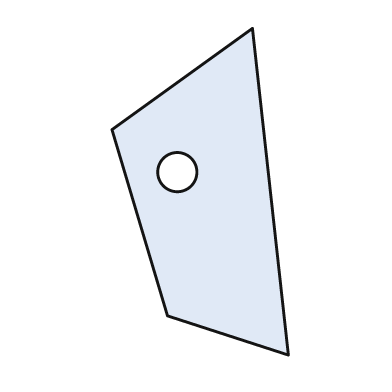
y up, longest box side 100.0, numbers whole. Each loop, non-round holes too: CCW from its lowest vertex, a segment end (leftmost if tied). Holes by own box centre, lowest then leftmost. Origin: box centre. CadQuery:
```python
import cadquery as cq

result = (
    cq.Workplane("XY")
    .moveTo(27.0, -50.0)
    .lineTo(16.0, 50.0)
    .lineTo(-27.0, 19.0)
    .lineTo(-10.0, -38.0)
    .close()
    .moveTo(-7.0, 6.0)
    .circle(6.0)
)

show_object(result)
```